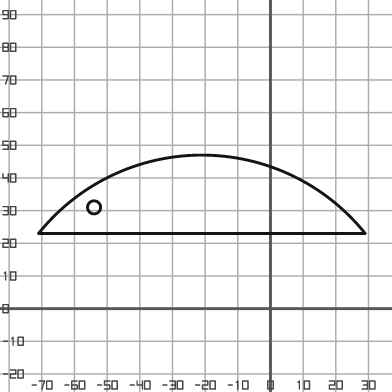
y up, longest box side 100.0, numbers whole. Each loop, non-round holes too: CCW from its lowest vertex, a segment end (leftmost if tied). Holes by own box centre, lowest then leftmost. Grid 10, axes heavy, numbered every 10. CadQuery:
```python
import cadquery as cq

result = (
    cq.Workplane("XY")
    .moveTo(-71.0, 23.0)
    .lineTo(29.0, 23.0)
    .threePointArc((-21.0, 47.0), (-71.0, 23.0))
    .close()
    .moveTo(-54.0, 31.0)
    .circle(2.0)
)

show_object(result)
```